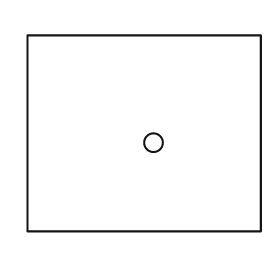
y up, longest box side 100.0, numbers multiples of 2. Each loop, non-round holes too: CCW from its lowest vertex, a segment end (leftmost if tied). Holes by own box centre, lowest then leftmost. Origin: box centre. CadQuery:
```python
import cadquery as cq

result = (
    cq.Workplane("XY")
    .moveTo(-50.0, -42.0)
    .lineTo(50.0, -42.0)
    .lineTo(50.0, 42.0)
    .lineTo(-50.0, 42.0)
    .close()
    .moveTo(4.0, -4.0)
    .circle(4.0)
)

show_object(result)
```